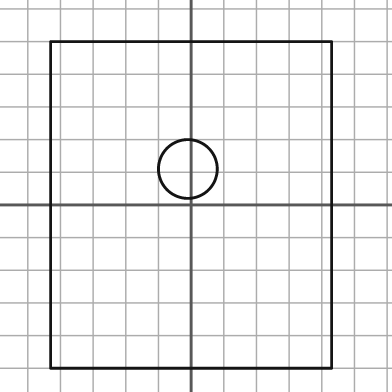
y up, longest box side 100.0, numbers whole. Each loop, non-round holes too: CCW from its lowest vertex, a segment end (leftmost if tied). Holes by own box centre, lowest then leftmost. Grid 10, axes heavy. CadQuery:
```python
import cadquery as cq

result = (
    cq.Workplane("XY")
    .moveTo(-43.0, -50.0)
    .lineTo(43.0, -50.0)
    .lineTo(43.0, 50.0)
    .lineTo(-43.0, 50.0)
    .close()
    .moveTo(-1.0, 11.0)
    .circle(9.0)
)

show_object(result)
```